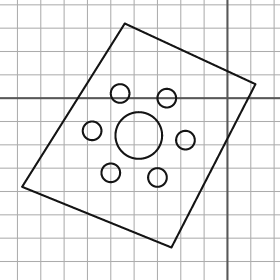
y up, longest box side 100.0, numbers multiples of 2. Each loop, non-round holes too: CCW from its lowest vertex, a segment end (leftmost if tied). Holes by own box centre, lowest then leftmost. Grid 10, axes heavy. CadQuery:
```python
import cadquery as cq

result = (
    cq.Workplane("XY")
    .moveTo(-24.0, -64.0)
    .lineTo(12.0, 6.0)
    .lineTo(-44.0, 32.0)
    .lineTo(-88.0, -38.0)
    .close()
    .moveTo(-30.0, -34.0)
    .circle(4.0)
    .moveTo(-50.0, -32.0)
    .circle(4.0)
    .moveTo(-18.0, -18.0)
    .circle(4.0)
    .moveTo(-38.0, -16.0)
    .circle(10.0)
    .moveTo(-58.0, -14.0)
    .circle(4.0)
    .moveTo(-26.0, 0.0)
    .circle(4.0)
    .moveTo(-46.0, 2.0)
    .circle(4.0)
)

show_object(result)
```